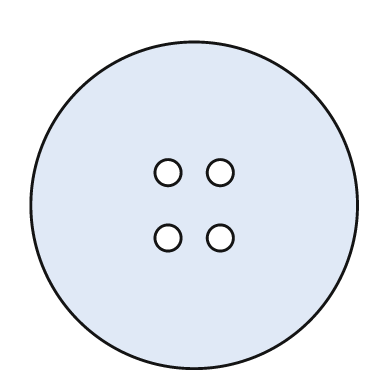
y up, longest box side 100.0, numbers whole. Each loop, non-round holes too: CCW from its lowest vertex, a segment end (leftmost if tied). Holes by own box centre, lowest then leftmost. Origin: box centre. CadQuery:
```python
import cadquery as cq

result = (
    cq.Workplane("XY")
    .moveTo(0.0, 0.0)
    .circle(50.0)
    .moveTo(-8.0, -10.0)
    .circle(4.0)
    .moveTo(8.0, -10.0)
    .circle(4.0)
    .moveTo(-8.0, 10.0)
    .circle(4.0)
    .moveTo(8.0, 10.0)
    .circle(4.0)
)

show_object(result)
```